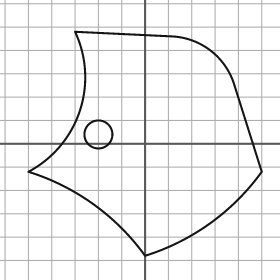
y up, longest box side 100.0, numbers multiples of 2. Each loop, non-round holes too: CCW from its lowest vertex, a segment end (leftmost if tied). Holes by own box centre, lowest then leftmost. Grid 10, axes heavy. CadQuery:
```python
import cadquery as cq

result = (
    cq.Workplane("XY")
    .moveTo(0.0, -48.0)
    .threePointArc((28.0, -34.0), (50.0, -12.0))
    .lineTo(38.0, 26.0)
    .threePointArc((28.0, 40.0), (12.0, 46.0))
    .lineTo(-30.0, 48.0)
    .threePointArc((-28.0, 14.0), (-50.0, -12.0))
    .threePointArc((-22.0, -26.0), (0.0, -48.0))
    .close()
    .moveTo(-20.0, 4.0)
    .circle(6.0)
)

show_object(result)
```